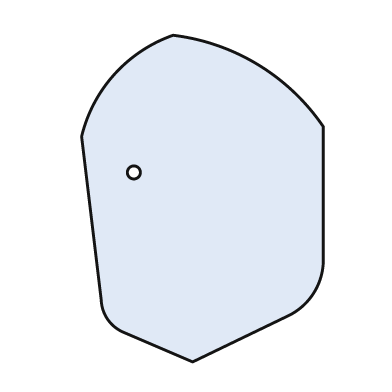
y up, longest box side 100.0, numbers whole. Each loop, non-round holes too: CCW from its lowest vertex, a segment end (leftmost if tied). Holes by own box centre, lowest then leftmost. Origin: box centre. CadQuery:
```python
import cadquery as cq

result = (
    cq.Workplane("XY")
    .moveTo(-3.0, -50.0)
    .lineTo(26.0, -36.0)
    .threePointArc((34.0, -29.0), (37.0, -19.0))
    .lineTo(37.0, 22.0)
    .threePointArc((17.0, 41.0), (-9.0, 50.0))
    .threePointArc((-27.0, 38.0), (-37.0, 19.0))
    .lineTo(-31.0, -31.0)
    .threePointArc((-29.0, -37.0), (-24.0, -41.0))
    .close()
    .moveTo(-21.0, 8.0)
    .circle(2.0)
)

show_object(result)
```